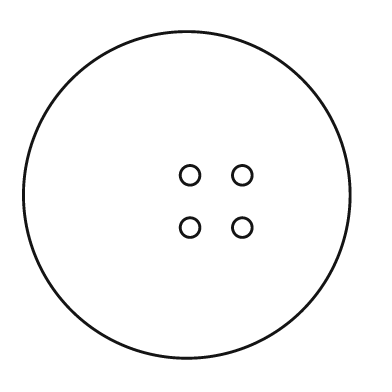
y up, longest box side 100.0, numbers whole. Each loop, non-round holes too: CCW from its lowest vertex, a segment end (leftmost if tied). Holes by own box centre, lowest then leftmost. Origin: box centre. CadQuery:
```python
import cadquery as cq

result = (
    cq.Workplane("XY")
    .moveTo(0.0, 0.0)
    .circle(50.0)
    .moveTo(1.0, -10.0)
    .circle(3.0)
    .moveTo(17.0, -10.0)
    .circle(3.0)
    .moveTo(1.0, 6.0)
    .circle(3.0)
    .moveTo(17.0, 6.0)
    .circle(3.0)
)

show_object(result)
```